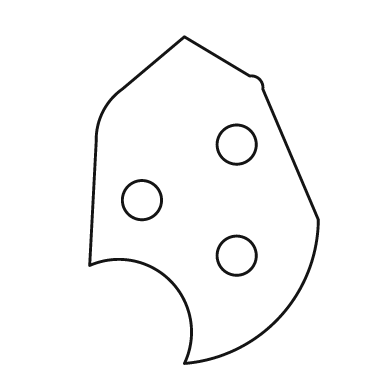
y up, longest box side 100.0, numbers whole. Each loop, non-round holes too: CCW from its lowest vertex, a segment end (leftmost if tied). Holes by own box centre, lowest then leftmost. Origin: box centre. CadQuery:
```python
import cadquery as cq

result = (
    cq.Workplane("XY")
    .moveTo(-6.0, -50.0)
    .threePointArc((23.0, -36.0), (35.0, -6.0))
    .lineTo(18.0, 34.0)
    .threePointArc((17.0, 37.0), (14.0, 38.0))
    .lineTo(-6.0, 50.0)
    .lineTo(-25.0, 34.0)
    .threePointArc((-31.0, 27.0), (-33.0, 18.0))
    .lineTo(-35.0, -20.0)
    .threePointArc((-10.0, -25.0), (-6.0, -50.0))
    .close()
    .moveTo(10.0, -17.0)
    .circle(6.0)
    .moveTo(-19.0, 0.0)
    .circle(6.0)
    .moveTo(10.0, 17.0)
    .circle(6.0)
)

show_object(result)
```